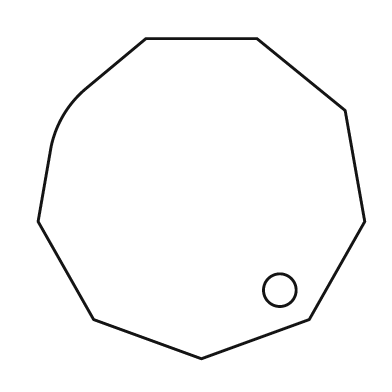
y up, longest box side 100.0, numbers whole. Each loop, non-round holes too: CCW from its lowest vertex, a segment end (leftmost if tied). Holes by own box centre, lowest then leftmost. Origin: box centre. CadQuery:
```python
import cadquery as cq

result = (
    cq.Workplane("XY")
    .moveTo(0.0, -49.0)
    .lineTo(33.0, -37.0)
    .lineTo(50.0, -7.0)
    .lineTo(44.0, 27.0)
    .lineTo(17.0, 49.0)
    .lineTo(-17.0, 49.0)
    .lineTo(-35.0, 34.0)
    .threePointArc((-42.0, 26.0), (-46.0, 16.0))
    .lineTo(-50.0, -7.0)
    .lineTo(-33.0, -37.0)
    .close()
    .moveTo(24.0, -28.0)
    .circle(5.0)
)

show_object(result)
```